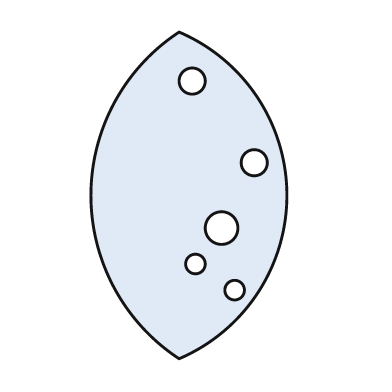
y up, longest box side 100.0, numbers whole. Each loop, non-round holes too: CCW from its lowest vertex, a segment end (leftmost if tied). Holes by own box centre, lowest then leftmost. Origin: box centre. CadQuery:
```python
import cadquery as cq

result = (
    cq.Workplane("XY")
    .moveTo(-3.0, -50.0)
    .threePointArc((30.0, 0.0), (-3.0, 50.0))
    .threePointArc((-30.0, 0.0), (-3.0, -50.0))
    .close()
    .moveTo(14.0, -29.0)
    .circle(3.0)
    .moveTo(2.0, -21.0)
    .circle(3.0)
    .moveTo(10.0, -10.0)
    .circle(5.0)
    .moveTo(20.0, 10.0)
    .circle(4.0)
    .moveTo(1.0, 35.0)
    .circle(4.0)
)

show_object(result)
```